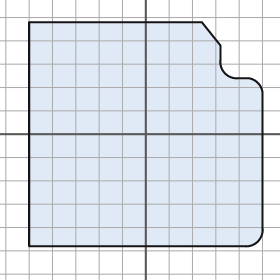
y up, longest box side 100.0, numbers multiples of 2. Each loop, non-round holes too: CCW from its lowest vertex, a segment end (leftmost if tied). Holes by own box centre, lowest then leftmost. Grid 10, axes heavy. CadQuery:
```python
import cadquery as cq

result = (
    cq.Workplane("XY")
    .moveTo(-50.0, -48.0)
    .lineTo(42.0, -48.0)
    .threePointArc((48.0, -46.0), (50.0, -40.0))
    .lineTo(50.0, 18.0)
    .threePointArc((48.0, 22.0), (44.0, 24.0))
    .lineTo(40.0, 24.0)
    .threePointArc((34.0, 26.0), (32.0, 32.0))
    .lineTo(32.0, 38.0)
    .lineTo(24.0, 48.0)
    .lineTo(-50.0, 48.0)
    .close()
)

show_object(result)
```